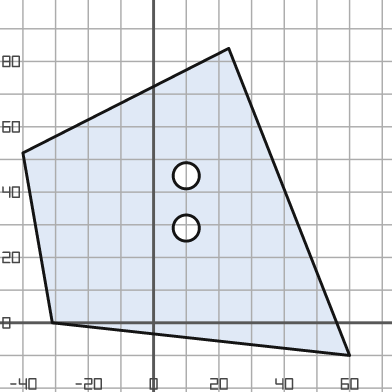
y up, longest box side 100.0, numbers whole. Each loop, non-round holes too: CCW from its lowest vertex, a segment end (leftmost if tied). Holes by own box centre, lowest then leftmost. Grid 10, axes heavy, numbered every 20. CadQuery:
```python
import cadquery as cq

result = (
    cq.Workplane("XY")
    .moveTo(60.0, -10.0)
    .lineTo(23.0, 84.0)
    .lineTo(-40.0, 52.0)
    .lineTo(-31.0, 0.0)
    .close()
    .moveTo(10.0, 29.0)
    .circle(4.0)
    .moveTo(10.0, 45.0)
    .circle(4.0)
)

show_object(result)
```